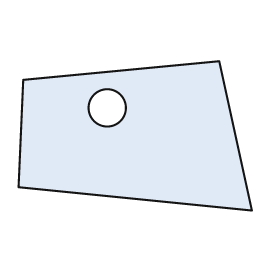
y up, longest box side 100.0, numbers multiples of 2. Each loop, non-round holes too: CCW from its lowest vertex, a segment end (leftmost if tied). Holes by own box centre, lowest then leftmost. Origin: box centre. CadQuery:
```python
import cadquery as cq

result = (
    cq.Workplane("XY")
    .moveTo(50.0, -32.0)
    .lineTo(36.0, 32.0)
    .lineTo(-48.0, 24.0)
    .lineTo(-50.0, -22.0)
    .close()
    .moveTo(-12.0, 12.0)
    .circle(8.0)
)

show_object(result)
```